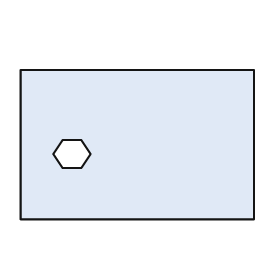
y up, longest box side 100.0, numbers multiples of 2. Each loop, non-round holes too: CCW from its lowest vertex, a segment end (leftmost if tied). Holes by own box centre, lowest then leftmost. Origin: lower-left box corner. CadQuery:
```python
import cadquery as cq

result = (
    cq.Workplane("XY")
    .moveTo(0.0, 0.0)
    .lineTo(100.0, 0.0)
    .lineTo(100.0, 64.0)
    .lineTo(0.0, 64.0)
    .close()
    .moveTo(18.0, 22.0)
    .lineTo(26.0, 22.0)
    .lineTo(30.0, 28.0)
    .lineTo(26.0, 34.0)
    .lineTo(18.0, 34.0)
    .lineTo(14.0, 28.0)
    .close()
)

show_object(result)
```